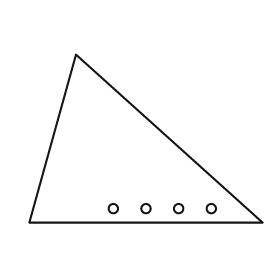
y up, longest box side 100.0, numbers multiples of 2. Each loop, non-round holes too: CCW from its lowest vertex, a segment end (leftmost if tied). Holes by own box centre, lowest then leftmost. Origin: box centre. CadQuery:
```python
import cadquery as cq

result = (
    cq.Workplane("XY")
    .moveTo(-50.0, -36.0)
    .lineTo(50.0, -36.0)
    .lineTo(-30.0, 36.0)
    .close()
    .moveTo(-14.0, -30.0)
    .circle(2.0)
    .moveTo(0.0, -30.0)
    .circle(2.0)
    .moveTo(14.0, -30.0)
    .circle(2.0)
    .moveTo(28.0, -30.0)
    .circle(2.0)
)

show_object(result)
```